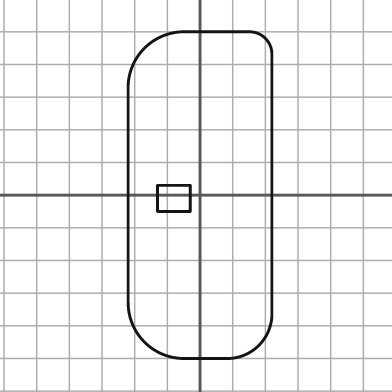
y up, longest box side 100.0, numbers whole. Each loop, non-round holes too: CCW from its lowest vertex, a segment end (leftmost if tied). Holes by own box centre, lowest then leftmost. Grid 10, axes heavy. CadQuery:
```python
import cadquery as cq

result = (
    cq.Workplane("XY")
    .moveTo(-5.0, -50.0)
    .lineTo(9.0, -50.0)
    .threePointArc((18.0, -46.0), (22.0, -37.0))
    .lineTo(22.0, 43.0)
    .threePointArc((20.0, 48.0), (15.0, 50.0))
    .lineTo(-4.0, 50.0)
    .threePointArc((-17.0, 45.0), (-22.0, 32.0))
    .lineTo(-22.0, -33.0)
    .threePointArc((-17.0, -45.0), (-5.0, -50.0))
    .close()
    .moveTo(-13.0, -5.0)
    .lineTo(-3.0, -5.0)
    .lineTo(-3.0, 3.0)
    .lineTo(-13.0, 3.0)
    .close()
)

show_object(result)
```